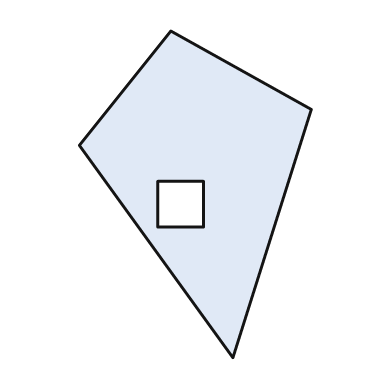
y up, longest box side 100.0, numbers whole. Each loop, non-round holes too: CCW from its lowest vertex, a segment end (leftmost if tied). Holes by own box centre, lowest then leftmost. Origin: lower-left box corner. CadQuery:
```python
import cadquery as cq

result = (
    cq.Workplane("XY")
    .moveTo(47.0, 0.0)
    .lineTo(71.0, 76.0)
    .lineTo(28.0, 100.0)
    .lineTo(0.0, 65.0)
    .close()
    .moveTo(24.0, 40.0)
    .lineTo(38.0, 40.0)
    .lineTo(38.0, 54.0)
    .lineTo(24.0, 54.0)
    .close()
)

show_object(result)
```